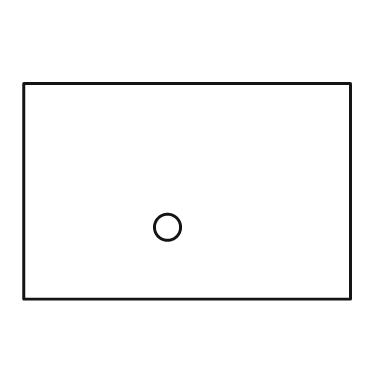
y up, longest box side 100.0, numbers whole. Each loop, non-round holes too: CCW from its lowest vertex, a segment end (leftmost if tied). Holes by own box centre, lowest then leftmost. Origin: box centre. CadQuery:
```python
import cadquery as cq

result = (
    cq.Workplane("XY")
    .moveTo(-50.0, -33.0)
    .lineTo(50.0, -33.0)
    .lineTo(50.0, 33.0)
    .lineTo(-50.0, 33.0)
    .close()
    .moveTo(-6.0, -11.0)
    .circle(4.0)
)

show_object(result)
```